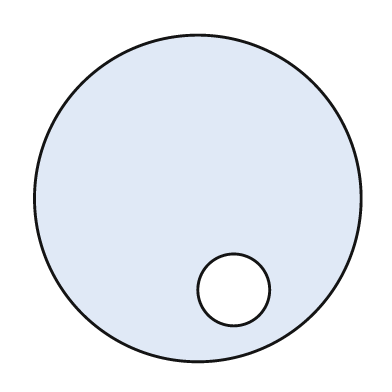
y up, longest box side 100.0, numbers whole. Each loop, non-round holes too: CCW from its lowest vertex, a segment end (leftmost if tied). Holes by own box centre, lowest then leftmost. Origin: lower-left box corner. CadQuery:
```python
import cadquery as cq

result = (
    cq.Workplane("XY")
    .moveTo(50.0, 50.0)
    .circle(50.0)
    .moveTo(61.0, 22.0)
    .circle(11.0)
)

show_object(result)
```